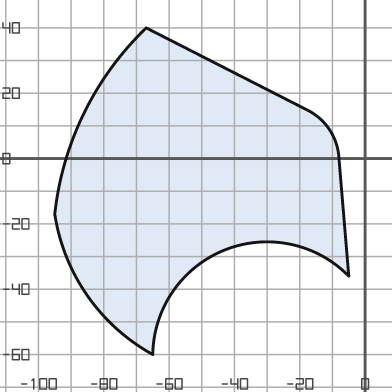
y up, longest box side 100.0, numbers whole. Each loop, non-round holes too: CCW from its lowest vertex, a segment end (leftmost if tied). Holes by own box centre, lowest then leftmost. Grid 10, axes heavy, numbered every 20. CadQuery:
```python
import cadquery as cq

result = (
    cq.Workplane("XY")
    .moveTo(-65.0, -60.0)
    .threePointArc((-43.0, -28.0), (-5.0, -36.0))
    .lineTo(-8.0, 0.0)
    .threePointArc((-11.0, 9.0), (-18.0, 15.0))
    .lineTo(-67.0, 40.0)
    .threePointArc((-86.0, 14.0), (-95.0, -17.0))
    .threePointArc((-85.0, -42.0), (-65.0, -60.0))
    .close()
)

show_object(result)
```